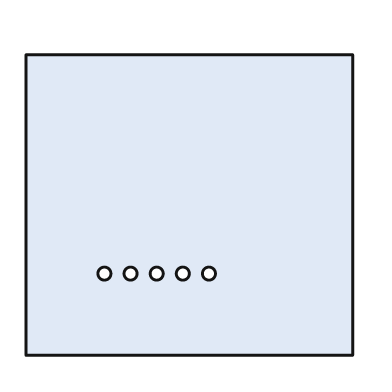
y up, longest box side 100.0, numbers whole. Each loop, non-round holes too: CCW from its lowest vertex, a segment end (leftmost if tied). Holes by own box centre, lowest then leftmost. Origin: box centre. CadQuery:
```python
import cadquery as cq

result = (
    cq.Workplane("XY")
    .moveTo(-50.0, -46.0)
    .lineTo(50.0, -46.0)
    .lineTo(50.0, 46.0)
    .lineTo(-50.0, 46.0)
    .close()
    .moveTo(-26.0, -21.0)
    .circle(2.0)
    .moveTo(-18.0, -21.0)
    .circle(2.0)
    .moveTo(-10.0, -21.0)
    .circle(2.0)
    .moveTo(-2.0, -21.0)
    .circle(2.0)
    .moveTo(6.0, -21.0)
    .circle(2.0)
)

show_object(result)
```